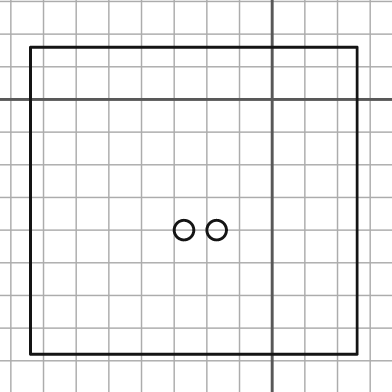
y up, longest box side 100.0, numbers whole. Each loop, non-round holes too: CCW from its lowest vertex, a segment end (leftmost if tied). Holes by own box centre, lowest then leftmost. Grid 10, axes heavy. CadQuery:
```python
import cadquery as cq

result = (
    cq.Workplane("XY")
    .moveTo(-74.0, -78.0)
    .lineTo(26.0, -78.0)
    .lineTo(26.0, 16.0)
    .lineTo(-74.0, 16.0)
    .close()
    .moveTo(-27.0, -40.0)
    .circle(3.0)
    .moveTo(-17.0, -40.0)
    .circle(3.0)
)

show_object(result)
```